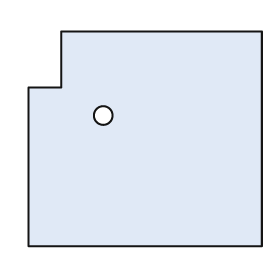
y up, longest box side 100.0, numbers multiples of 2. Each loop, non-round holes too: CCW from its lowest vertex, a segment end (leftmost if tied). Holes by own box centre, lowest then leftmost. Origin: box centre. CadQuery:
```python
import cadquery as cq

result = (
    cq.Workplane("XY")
    .moveTo(-50.0, -46.0)
    .lineTo(50.0, -46.0)
    .lineTo(50.0, 46.0)
    .lineTo(-36.0, 46.0)
    .lineTo(-36.0, 22.0)
    .lineTo(-50.0, 22.0)
    .close()
    .moveTo(-18.0, 10.0)
    .circle(4.0)
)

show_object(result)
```